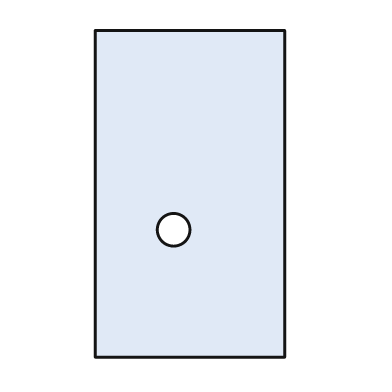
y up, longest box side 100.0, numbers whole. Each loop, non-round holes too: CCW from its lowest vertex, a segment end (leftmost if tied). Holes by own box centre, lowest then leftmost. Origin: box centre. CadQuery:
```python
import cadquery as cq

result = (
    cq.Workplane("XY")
    .moveTo(-29.0, -50.0)
    .lineTo(29.0, -50.0)
    .lineTo(29.0, 50.0)
    .lineTo(-29.0, 50.0)
    .close()
    .moveTo(-5.0, -11.0)
    .circle(5.0)
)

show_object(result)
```